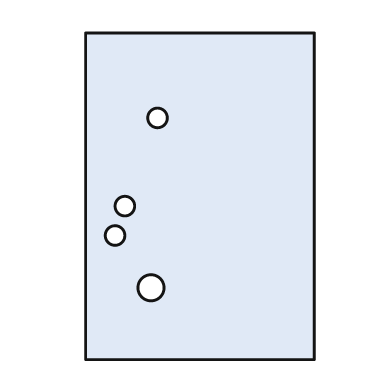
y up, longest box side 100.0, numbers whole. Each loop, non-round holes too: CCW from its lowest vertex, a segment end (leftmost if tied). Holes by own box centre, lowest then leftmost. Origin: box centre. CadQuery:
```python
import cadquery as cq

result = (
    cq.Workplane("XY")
    .moveTo(-35.0, -50.0)
    .lineTo(35.0, -50.0)
    .lineTo(35.0, 50.0)
    .lineTo(-35.0, 50.0)
    .close()
    .moveTo(-15.0, -28.0)
    .circle(4.0)
    .moveTo(-26.0, -12.0)
    .circle(3.0)
    .moveTo(-23.0, -3.0)
    .circle(3.0)
    .moveTo(-13.0, 24.0)
    .circle(3.0)
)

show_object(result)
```